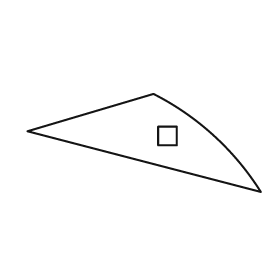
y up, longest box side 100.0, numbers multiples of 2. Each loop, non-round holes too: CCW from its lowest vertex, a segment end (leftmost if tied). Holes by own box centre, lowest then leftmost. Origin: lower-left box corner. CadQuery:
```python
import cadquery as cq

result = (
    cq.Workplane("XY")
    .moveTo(100.0, 0.0)
    .threePointArc((80.0, 24.0), (54.0, 42.0))
    .lineTo(0.0, 26.0)
    .close()
    .moveTo(56.0, 20.0)
    .lineTo(64.0, 20.0)
    .lineTo(64.0, 28.0)
    .lineTo(56.0, 28.0)
    .close()
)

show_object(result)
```